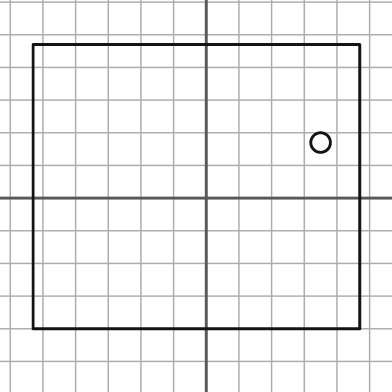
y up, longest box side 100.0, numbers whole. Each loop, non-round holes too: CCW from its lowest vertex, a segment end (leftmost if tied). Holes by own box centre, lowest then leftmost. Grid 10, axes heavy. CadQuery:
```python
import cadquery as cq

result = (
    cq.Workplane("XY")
    .moveTo(-53.0, -40.0)
    .lineTo(47.0, -40.0)
    .lineTo(47.0, 47.0)
    .lineTo(-53.0, 47.0)
    .close()
    .moveTo(35.0, 17.0)
    .circle(3.0)
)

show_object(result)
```